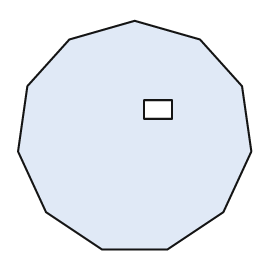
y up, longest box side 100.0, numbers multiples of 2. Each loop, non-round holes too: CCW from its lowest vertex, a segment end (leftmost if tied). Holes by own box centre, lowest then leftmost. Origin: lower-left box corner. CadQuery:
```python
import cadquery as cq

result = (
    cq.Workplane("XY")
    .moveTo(36.0, 0.0)
    .lineTo(64.0, 0.0)
    .lineTo(88.0, 16.0)
    .lineTo(100.0, 42.0)
    .lineTo(96.0, 70.0)
    .lineTo(78.0, 90.0)
    .lineTo(50.0, 98.0)
    .lineTo(22.0, 90.0)
    .lineTo(4.0, 70.0)
    .lineTo(0.0, 42.0)
    .lineTo(12.0, 16.0)
    .close()
    .moveTo(54.0, 56.0)
    .lineTo(66.0, 56.0)
    .lineTo(66.0, 64.0)
    .lineTo(54.0, 64.0)
    .close()
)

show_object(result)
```